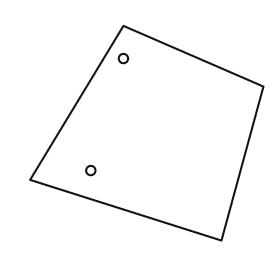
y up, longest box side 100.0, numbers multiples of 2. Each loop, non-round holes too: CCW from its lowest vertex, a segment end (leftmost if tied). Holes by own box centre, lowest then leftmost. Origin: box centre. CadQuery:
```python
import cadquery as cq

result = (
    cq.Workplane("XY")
    .moveTo(32.0, -46.0)
    .lineTo(50.0, 20.0)
    .lineTo(-10.0, 46.0)
    .lineTo(-50.0, -20.0)
    .close()
    .moveTo(-24.0, -16.0)
    .circle(2.0)
    .moveTo(-10.0, 32.0)
    .circle(2.0)
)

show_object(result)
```